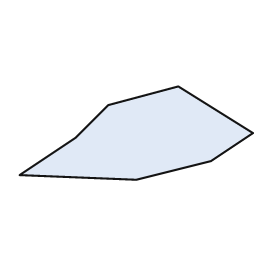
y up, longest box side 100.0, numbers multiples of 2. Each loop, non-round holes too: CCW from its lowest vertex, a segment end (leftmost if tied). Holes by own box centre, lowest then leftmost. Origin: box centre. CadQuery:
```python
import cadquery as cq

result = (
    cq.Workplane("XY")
    .moveTo(0.0, -20.0)
    .lineTo(32.0, -12.0)
    .lineTo(50.0, 0.0)
    .lineTo(18.0, 20.0)
    .lineTo(-12.0, 12.0)
    .lineTo(-26.0, -2.0)
    .lineTo(-50.0, -18.0)
    .close()
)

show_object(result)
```